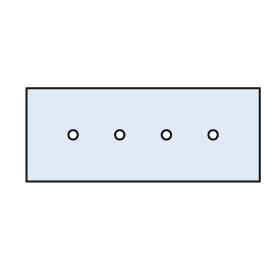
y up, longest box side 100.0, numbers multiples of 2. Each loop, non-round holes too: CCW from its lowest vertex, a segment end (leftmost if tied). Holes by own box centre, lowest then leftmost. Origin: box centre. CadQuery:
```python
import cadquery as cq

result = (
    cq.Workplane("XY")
    .moveTo(-50.0, -20.0)
    .lineTo(50.0, -20.0)
    .lineTo(50.0, 20.0)
    .lineTo(-50.0, 20.0)
    .close()
    .moveTo(-30.0, 0.0)
    .circle(2.0)
    .moveTo(-10.0, 0.0)
    .circle(2.0)
    .moveTo(10.0, 0.0)
    .circle(2.0)
    .moveTo(30.0, 0.0)
    .circle(2.0)
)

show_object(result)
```